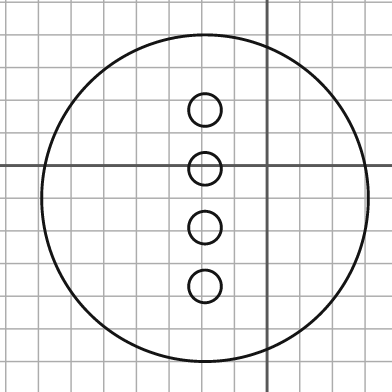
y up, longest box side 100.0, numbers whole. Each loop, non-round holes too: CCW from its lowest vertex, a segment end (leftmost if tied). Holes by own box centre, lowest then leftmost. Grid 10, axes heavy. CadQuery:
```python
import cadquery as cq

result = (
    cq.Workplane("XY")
    .moveTo(-19.0, -10.0)
    .circle(50.0)
    .moveTo(-19.0, -37.0)
    .circle(5.0)
    .moveTo(-19.0, -19.0)
    .circle(5.0)
    .moveTo(-19.0, -1.0)
    .circle(5.0)
    .moveTo(-19.0, 17.0)
    .circle(5.0)
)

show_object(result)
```